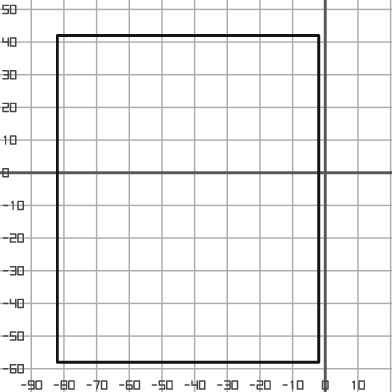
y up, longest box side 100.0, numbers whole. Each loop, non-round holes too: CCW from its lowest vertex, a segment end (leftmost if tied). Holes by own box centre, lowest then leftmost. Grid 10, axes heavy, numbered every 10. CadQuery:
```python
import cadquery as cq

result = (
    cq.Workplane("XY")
    .moveTo(-82.0, -58.0)
    .lineTo(-2.0, -58.0)
    .lineTo(-2.0, 42.0)
    .lineTo(-82.0, 42.0)
    .close()
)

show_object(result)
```